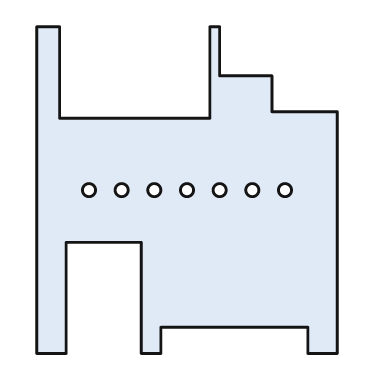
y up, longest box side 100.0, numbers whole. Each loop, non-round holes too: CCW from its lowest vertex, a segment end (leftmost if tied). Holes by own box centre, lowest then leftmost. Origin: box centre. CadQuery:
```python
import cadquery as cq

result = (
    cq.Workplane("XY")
    .moveTo(-46.0, -50.0)
    .lineTo(-37.0, -50.0)
    .lineTo(-37.0, -16.0)
    .lineTo(-14.0, -16.0)
    .lineTo(-14.0, -50.0)
    .lineTo(-8.0, -50.0)
    .lineTo(-8.0, -42.0)
    .lineTo(37.0, -42.0)
    .lineTo(37.0, -50.0)
    .lineTo(46.0, -50.0)
    .lineTo(46.0, 24.0)
    .lineTo(26.0, 24.0)
    .lineTo(26.0, 35.0)
    .lineTo(10.0, 35.0)
    .lineTo(10.0, 50.0)
    .lineTo(7.0, 50.0)
    .lineTo(7.0, 22.0)
    .lineTo(-39.0, 22.0)
    .lineTo(-39.0, 50.0)
    .lineTo(-46.0, 50.0)
    .close()
    .moveTo(-30.0, 0.0)
    .circle(2.0)
    .moveTo(-20.0, 0.0)
    .circle(2.0)
    .moveTo(-10.0, 0.0)
    .circle(2.0)
    .moveTo(0.0, 0.0)
    .circle(2.0)
    .moveTo(10.0, 0.0)
    .circle(2.0)
    .moveTo(20.0, 0.0)
    .circle(2.0)
    .moveTo(30.0, 0.0)
    .circle(2.0)
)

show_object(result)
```